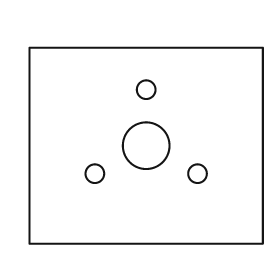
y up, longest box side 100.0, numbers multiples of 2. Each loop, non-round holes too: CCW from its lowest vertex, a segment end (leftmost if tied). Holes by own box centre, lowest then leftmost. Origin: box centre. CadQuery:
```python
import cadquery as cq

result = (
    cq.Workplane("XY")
    .moveTo(-50.0, -42.0)
    .lineTo(50.0, -42.0)
    .lineTo(50.0, 42.0)
    .lineTo(-50.0, 42.0)
    .close()
    .moveTo(-22.0, -12.0)
    .circle(4.0)
    .moveTo(22.0, -12.0)
    .circle(4.0)
    .moveTo(0.0, 0.0)
    .circle(10.0)
    .moveTo(0.0, 24.0)
    .circle(4.0)
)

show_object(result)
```